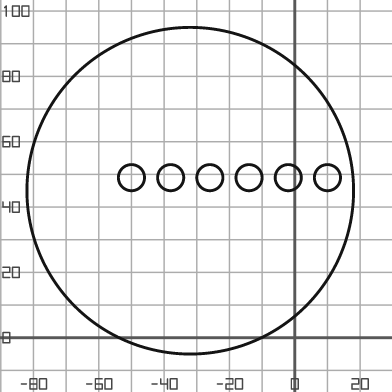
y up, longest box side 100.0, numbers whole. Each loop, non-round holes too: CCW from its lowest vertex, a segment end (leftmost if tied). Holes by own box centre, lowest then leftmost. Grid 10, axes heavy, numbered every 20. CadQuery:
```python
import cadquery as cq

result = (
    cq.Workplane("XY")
    .moveTo(-32.0, 45.0)
    .circle(50.0)
    .moveTo(-50.0, 49.0)
    .circle(4.0)
    .moveTo(-38.0, 49.0)
    .circle(4.0)
    .moveTo(-26.0, 49.0)
    .circle(4.0)
    .moveTo(-14.0, 49.0)
    .circle(4.0)
    .moveTo(-2.0, 49.0)
    .circle(4.0)
    .moveTo(10.0, 49.0)
    .circle(4.0)
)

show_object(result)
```